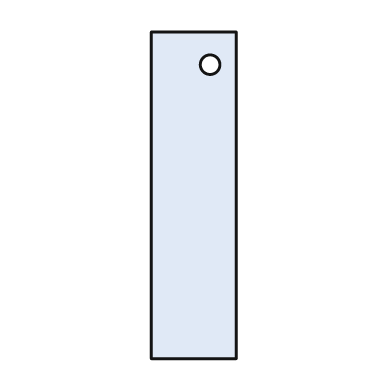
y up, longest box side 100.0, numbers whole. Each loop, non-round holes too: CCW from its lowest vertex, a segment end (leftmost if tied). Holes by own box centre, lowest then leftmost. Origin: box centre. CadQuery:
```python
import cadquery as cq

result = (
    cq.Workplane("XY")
    .moveTo(-13.0, -50.0)
    .lineTo(13.0, -50.0)
    .lineTo(13.0, 50.0)
    .lineTo(-13.0, 50.0)
    .close()
    .moveTo(5.0, 40.0)
    .circle(3.0)
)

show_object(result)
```